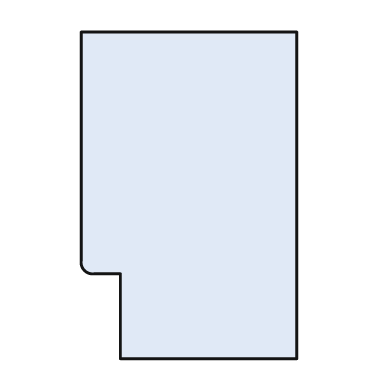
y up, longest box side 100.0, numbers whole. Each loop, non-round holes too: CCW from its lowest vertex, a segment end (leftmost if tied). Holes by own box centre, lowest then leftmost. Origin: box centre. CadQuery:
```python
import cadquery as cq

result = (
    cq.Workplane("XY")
    .moveTo(-21.0, -50.0)
    .lineTo(33.0, -50.0)
    .lineTo(33.0, 50.0)
    .lineTo(-33.0, 50.0)
    .lineTo(-33.0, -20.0)
    .threePointArc((-32.0, -23.0), (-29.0, -24.0))
    .lineTo(-21.0, -24.0)
    .close()
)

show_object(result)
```